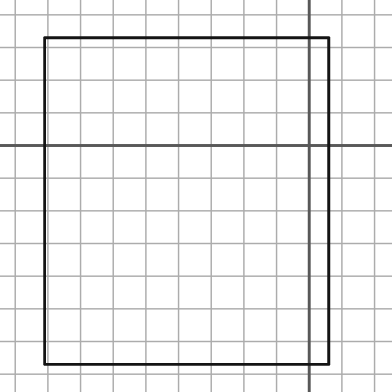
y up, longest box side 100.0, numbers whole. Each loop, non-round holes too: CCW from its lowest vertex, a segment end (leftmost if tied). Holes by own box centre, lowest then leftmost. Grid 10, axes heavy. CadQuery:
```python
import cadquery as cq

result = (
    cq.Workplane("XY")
    .moveTo(-81.0, -67.0)
    .lineTo(6.0, -67.0)
    .lineTo(6.0, 33.0)
    .lineTo(-81.0, 33.0)
    .close()
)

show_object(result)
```